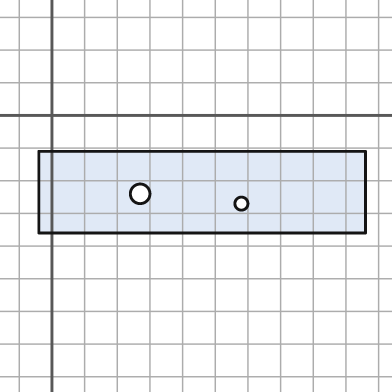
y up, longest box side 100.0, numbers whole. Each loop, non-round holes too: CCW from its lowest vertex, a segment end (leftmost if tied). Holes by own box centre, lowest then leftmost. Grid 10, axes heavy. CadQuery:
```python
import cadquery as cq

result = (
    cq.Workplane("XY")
    .moveTo(-4.0, -36.0)
    .lineTo(96.0, -36.0)
    .lineTo(96.0, -11.0)
    .lineTo(-4.0, -11.0)
    .close()
    .moveTo(58.0, -27.0)
    .circle(2.0)
    .moveTo(27.0, -24.0)
    .circle(3.0)
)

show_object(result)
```